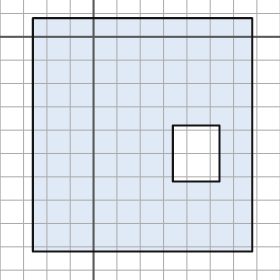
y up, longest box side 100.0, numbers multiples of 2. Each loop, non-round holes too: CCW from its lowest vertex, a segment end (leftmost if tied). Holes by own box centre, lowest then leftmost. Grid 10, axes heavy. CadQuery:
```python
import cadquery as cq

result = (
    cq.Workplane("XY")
    .moveTo(-26.0, -92.0)
    .lineTo(68.0, -92.0)
    .lineTo(68.0, 8.0)
    .lineTo(-26.0, 8.0)
    .close()
    .moveTo(34.0, -62.0)
    .lineTo(54.0, -62.0)
    .lineTo(54.0, -38.0)
    .lineTo(34.0, -38.0)
    .close()
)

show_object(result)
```